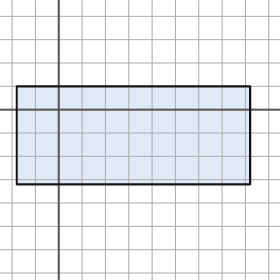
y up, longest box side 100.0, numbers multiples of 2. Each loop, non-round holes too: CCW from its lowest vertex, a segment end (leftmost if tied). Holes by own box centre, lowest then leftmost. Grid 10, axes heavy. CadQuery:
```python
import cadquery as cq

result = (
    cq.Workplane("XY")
    .moveTo(-18.0, -32.0)
    .lineTo(82.0, -32.0)
    .lineTo(82.0, 10.0)
    .lineTo(-18.0, 10.0)
    .close()
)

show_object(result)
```